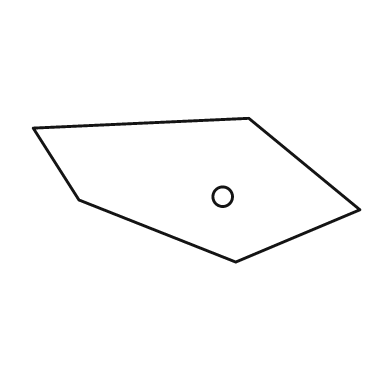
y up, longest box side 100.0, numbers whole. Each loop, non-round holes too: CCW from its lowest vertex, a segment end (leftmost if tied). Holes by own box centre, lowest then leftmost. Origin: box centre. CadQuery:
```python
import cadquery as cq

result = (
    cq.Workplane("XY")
    .moveTo(12.0, -22.0)
    .lineTo(50.0, -6.0)
    .lineTo(16.0, 22.0)
    .lineTo(-50.0, 19.0)
    .lineTo(-36.0, -3.0)
    .close()
    .moveTo(8.0, -2.0)
    .circle(3.0)
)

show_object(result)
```